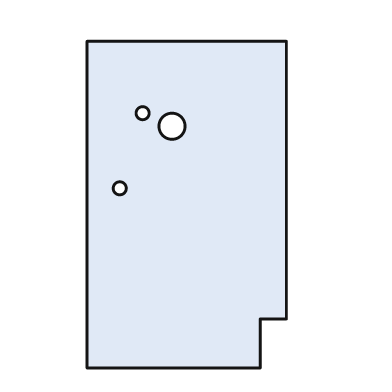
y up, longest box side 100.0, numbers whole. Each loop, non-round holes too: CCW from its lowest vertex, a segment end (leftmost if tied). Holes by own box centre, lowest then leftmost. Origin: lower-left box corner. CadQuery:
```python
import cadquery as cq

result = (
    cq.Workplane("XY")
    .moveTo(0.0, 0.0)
    .lineTo(53.0, 0.0)
    .lineTo(53.0, 15.0)
    .lineTo(61.0, 15.0)
    .lineTo(61.0, 100.0)
    .lineTo(0.0, 100.0)
    .close()
    .moveTo(10.0, 55.0)
    .circle(2.0)
    .moveTo(26.0, 74.0)
    .circle(4.0)
    .moveTo(17.0, 78.0)
    .circle(2.0)
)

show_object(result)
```